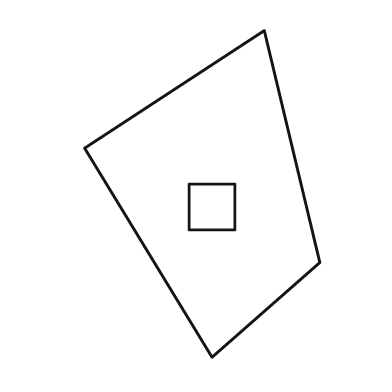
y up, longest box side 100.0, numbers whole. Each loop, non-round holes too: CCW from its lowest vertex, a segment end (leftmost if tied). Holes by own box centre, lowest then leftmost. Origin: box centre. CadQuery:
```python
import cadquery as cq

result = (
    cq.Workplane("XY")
    .moveTo(3.0, -50.0)
    .lineTo(36.0, -21.0)
    .lineTo(19.0, 50.0)
    .lineTo(-36.0, 14.0)
    .close()
    .moveTo(-4.0, -11.0)
    .lineTo(10.0, -11.0)
    .lineTo(10.0, 3.0)
    .lineTo(-4.0, 3.0)
    .close()
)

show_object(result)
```